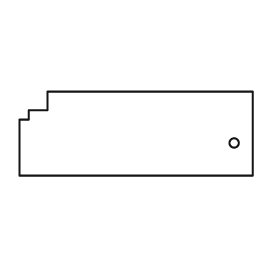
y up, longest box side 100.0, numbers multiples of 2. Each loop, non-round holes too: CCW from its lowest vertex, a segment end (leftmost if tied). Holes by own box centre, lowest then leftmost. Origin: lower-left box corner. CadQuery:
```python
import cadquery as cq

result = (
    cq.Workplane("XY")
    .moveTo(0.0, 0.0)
    .lineTo(100.0, 0.0)
    .lineTo(100.0, 36.0)
    .lineTo(12.0, 36.0)
    .lineTo(12.0, 28.0)
    .lineTo(4.0, 28.0)
    .lineTo(4.0, 24.0)
    .lineTo(0.0, 24.0)
    .close()
    .moveTo(92.0, 14.0)
    .circle(2.0)
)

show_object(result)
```